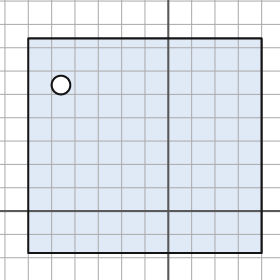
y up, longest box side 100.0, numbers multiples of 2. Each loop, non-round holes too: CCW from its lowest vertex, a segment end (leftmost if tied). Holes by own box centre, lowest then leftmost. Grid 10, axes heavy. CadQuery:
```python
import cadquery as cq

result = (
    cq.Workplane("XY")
    .moveTo(-60.0, -18.0)
    .lineTo(40.0, -18.0)
    .lineTo(40.0, 74.0)
    .lineTo(-60.0, 74.0)
    .close()
    .moveTo(-46.0, 54.0)
    .circle(4.0)
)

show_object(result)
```